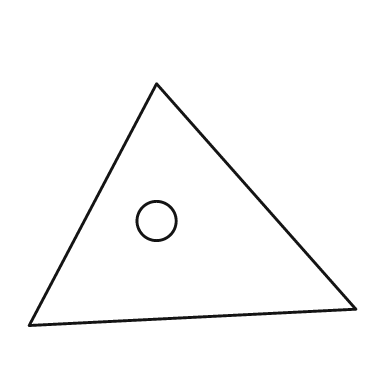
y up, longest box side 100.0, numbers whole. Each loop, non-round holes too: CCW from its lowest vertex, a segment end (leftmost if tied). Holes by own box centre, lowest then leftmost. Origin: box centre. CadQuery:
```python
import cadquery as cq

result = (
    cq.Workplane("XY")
    .moveTo(-50.0, -37.0)
    .lineTo(50.0, -32.0)
    .lineTo(-11.0, 37.0)
    .close()
    .moveTo(-11.0, -5.0)
    .circle(6.0)
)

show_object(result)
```